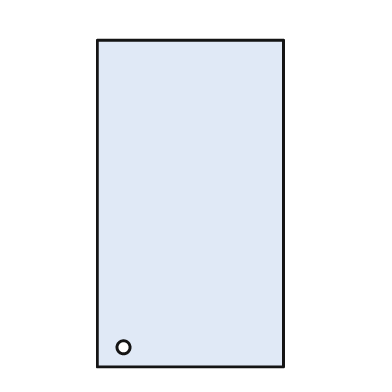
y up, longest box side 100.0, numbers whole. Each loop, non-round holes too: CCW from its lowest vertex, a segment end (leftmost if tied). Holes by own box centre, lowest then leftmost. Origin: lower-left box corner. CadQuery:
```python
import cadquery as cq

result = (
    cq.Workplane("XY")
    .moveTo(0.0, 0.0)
    .lineTo(57.0, 0.0)
    .lineTo(57.0, 100.0)
    .lineTo(0.0, 100.0)
    .close()
    .moveTo(8.0, 6.0)
    .circle(2.0)
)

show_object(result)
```